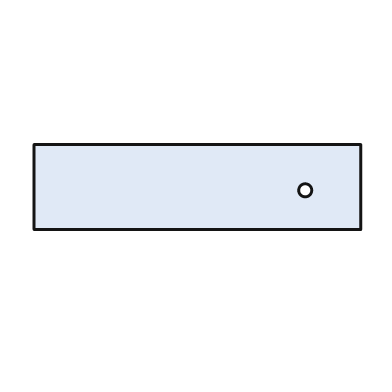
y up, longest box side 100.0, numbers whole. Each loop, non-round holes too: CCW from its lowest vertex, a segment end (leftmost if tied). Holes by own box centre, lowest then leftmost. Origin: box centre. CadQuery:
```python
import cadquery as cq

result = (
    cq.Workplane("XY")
    .moveTo(-50.0, -13.0)
    .lineTo(50.0, -13.0)
    .lineTo(50.0, 13.0)
    .lineTo(-50.0, 13.0)
    .close()
    .moveTo(33.0, -1.0)
    .circle(2.0)
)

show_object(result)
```